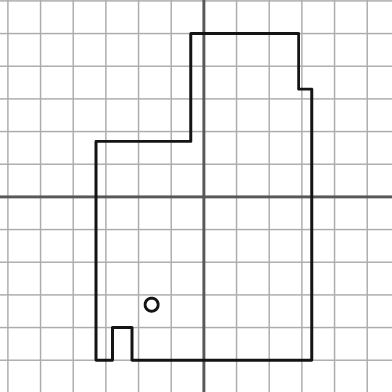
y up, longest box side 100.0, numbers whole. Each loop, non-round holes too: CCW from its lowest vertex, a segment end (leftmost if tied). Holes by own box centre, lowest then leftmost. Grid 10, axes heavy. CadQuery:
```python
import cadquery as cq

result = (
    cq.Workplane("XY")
    .moveTo(-33.0, -50.0)
    .lineTo(-28.0, -50.0)
    .lineTo(-28.0, -40.0)
    .lineTo(-22.0, -40.0)
    .lineTo(-22.0, -50.0)
    .lineTo(33.0, -50.0)
    .lineTo(33.0, 33.0)
    .lineTo(29.0, 33.0)
    .lineTo(29.0, 50.0)
    .lineTo(-4.0, 50.0)
    .lineTo(-4.0, 17.0)
    .lineTo(-33.0, 17.0)
    .close()
    .moveTo(-16.0, -33.0)
    .circle(2.0)
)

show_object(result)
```